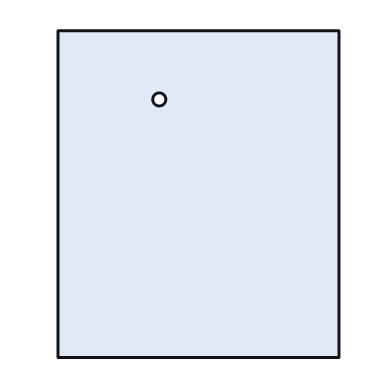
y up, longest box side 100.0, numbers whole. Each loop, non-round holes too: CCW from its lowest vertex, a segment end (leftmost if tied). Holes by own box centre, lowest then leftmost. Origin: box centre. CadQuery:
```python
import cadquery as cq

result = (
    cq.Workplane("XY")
    .moveTo(-43.0, -50.0)
    .lineTo(43.0, -50.0)
    .lineTo(43.0, 50.0)
    .lineTo(-43.0, 50.0)
    .close()
    .moveTo(-12.0, 29.0)
    .circle(2.0)
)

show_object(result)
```